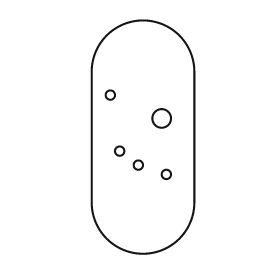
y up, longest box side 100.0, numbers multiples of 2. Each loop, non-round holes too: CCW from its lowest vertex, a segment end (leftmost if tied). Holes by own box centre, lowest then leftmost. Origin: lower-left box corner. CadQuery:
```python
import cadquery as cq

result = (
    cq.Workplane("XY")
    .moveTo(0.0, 22.0)
    .threePointArc((22.0, 0.0), (44.0, 22.0))
    .lineTo(44.0, 78.0)
    .threePointArc((22.0, 100.0), (0.0, 78.0))
    .close()
    .moveTo(32.0, 34.0)
    .circle(2.0)
    .moveTo(20.0, 38.0)
    .circle(2.0)
    .moveTo(12.0, 44.0)
    .circle(2.0)
    .moveTo(30.0, 58.0)
    .circle(4.0)
    .moveTo(8.0, 68.0)
    .circle(2.0)
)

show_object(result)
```